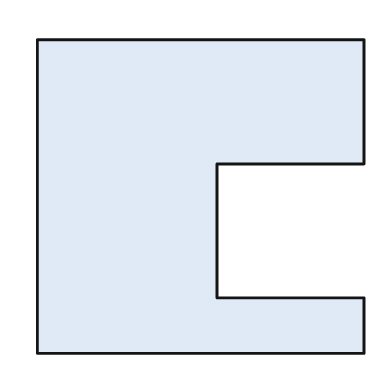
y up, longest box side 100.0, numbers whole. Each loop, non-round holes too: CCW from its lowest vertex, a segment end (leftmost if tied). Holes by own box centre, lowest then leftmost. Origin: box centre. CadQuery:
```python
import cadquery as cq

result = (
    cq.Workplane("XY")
    .moveTo(-50.0, -48.0)
    .lineTo(50.0, -48.0)
    .lineTo(50.0, -31.0)
    .lineTo(5.0, -31.0)
    .lineTo(5.0, 10.0)
    .lineTo(50.0, 10.0)
    .lineTo(50.0, 48.0)
    .lineTo(-50.0, 48.0)
    .close()
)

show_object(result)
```